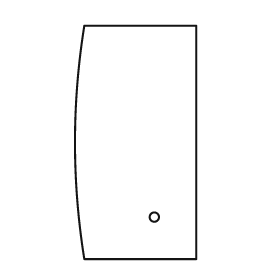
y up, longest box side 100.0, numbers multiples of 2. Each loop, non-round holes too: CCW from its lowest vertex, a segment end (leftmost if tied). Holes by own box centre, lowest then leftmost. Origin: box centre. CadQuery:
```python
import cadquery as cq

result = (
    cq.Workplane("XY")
    .moveTo(-22.0, -50.0)
    .lineTo(26.0, -50.0)
    .lineTo(26.0, 50.0)
    .lineTo(-22.0, 50.0)
    .threePointArc((-26.0, 0.0), (-22.0, -50.0))
    .close()
    .moveTo(8.0, -32.0)
    .circle(2.0)
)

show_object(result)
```